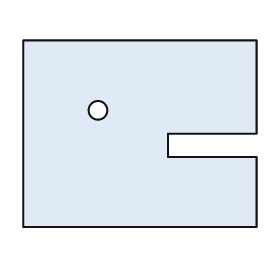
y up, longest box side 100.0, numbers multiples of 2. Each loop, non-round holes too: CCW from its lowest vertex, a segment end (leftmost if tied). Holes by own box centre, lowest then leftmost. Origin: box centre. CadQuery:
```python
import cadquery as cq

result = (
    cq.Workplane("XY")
    .moveTo(-50.0, -40.0)
    .lineTo(50.0, -40.0)
    .lineTo(50.0, -10.0)
    .lineTo(12.0, -10.0)
    .lineTo(12.0, 0.0)
    .lineTo(50.0, 0.0)
    .lineTo(50.0, 40.0)
    .lineTo(-50.0, 40.0)
    .close()
    .moveTo(-18.0, 10.0)
    .circle(4.0)
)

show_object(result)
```